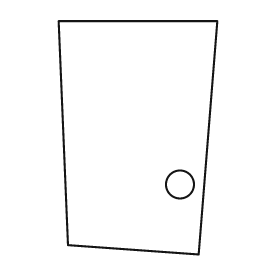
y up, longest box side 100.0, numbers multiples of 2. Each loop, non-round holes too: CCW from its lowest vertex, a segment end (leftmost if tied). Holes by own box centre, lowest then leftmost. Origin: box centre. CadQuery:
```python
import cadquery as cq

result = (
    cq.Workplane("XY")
    .moveTo(26.0, -50.0)
    .lineTo(34.0, 50.0)
    .lineTo(-34.0, 50.0)
    .lineTo(-30.0, -46.0)
    .close()
    .moveTo(18.0, -20.0)
    .circle(6.0)
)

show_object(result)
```